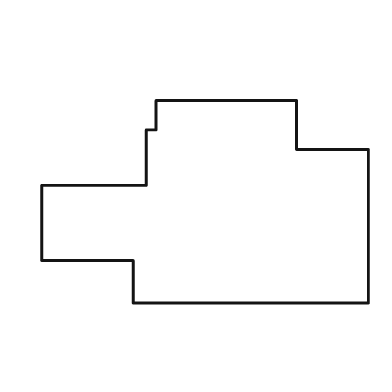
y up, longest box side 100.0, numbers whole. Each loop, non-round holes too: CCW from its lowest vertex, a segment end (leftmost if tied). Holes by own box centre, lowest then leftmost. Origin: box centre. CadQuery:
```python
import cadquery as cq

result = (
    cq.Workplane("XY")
    .moveTo(-22.0, -31.0)
    .lineTo(50.0, -31.0)
    .lineTo(50.0, 16.0)
    .lineTo(28.0, 16.0)
    .lineTo(28.0, 31.0)
    .lineTo(-15.0, 31.0)
    .lineTo(-15.0, 22.0)
    .lineTo(-18.0, 22.0)
    .lineTo(-18.0, 5.0)
    .lineTo(-50.0, 5.0)
    .lineTo(-50.0, -18.0)
    .lineTo(-22.0, -18.0)
    .close()
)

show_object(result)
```